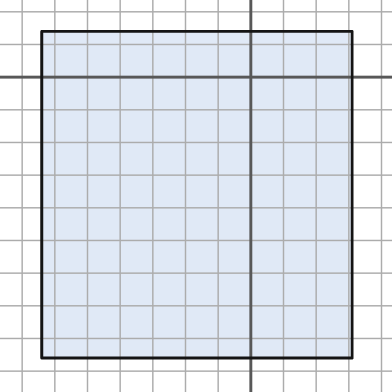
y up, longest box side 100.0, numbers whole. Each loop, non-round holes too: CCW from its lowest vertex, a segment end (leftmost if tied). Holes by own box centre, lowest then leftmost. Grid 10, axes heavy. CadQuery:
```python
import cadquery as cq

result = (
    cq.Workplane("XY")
    .moveTo(-64.0, -86.0)
    .lineTo(31.0, -86.0)
    .lineTo(31.0, 14.0)
    .lineTo(-64.0, 14.0)
    .close()
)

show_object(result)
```